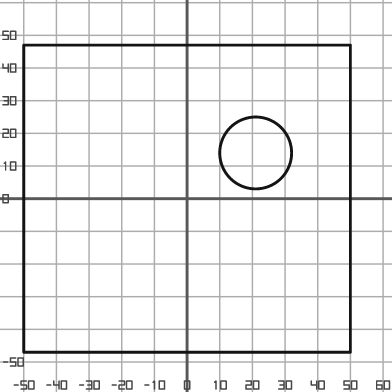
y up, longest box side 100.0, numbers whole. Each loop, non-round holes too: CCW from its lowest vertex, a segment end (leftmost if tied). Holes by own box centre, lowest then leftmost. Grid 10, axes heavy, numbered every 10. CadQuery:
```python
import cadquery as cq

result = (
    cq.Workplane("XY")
    .moveTo(-50.0, -47.0)
    .lineTo(50.0, -47.0)
    .lineTo(50.0, 47.0)
    .lineTo(-50.0, 47.0)
    .close()
    .moveTo(21.0, 14.0)
    .circle(11.0)
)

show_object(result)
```